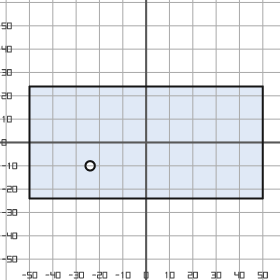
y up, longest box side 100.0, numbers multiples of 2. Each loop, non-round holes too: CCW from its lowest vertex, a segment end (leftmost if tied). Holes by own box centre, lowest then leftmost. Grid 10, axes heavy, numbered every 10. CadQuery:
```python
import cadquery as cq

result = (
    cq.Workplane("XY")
    .moveTo(-50.0, -24.0)
    .lineTo(50.0, -24.0)
    .lineTo(50.0, 24.0)
    .lineTo(-50.0, 24.0)
    .close()
    .moveTo(-24.0, -10.0)
    .circle(2.0)
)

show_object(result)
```